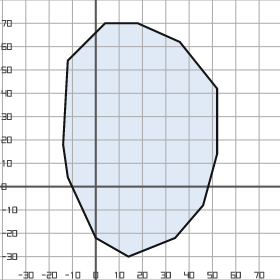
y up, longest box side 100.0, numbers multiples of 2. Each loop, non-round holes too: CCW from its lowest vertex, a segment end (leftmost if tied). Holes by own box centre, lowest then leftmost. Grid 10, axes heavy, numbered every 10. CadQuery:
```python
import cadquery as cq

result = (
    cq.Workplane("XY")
    .moveTo(14.0, -30.0)
    .lineTo(34.0, -22.0)
    .lineTo(46.0, -8.0)
    .lineTo(52.0, 14.0)
    .lineTo(52.0, 42.0)
    .lineTo(36.0, 62.0)
    .lineTo(18.0, 70.0)
    .lineTo(4.0, 70.0)
    .lineTo(-12.0, 54.0)
    .lineTo(-14.0, 18.0)
    .lineTo(-12.0, 4.0)
    .lineTo(0.0, -22.0)
    .close()
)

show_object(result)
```